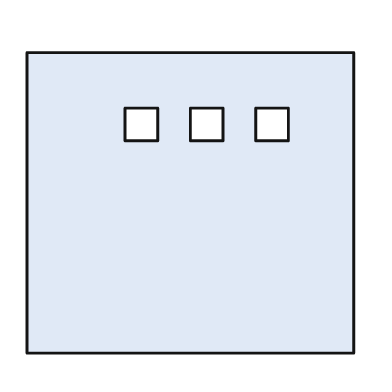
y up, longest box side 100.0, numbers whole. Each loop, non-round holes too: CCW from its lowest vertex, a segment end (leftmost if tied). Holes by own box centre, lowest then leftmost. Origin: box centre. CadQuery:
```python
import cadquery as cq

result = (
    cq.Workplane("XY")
    .moveTo(-50.0, -46.0)
    .lineTo(50.0, -46.0)
    .lineTo(50.0, 46.0)
    .lineTo(-50.0, 46.0)
    .close()
    .moveTo(-20.0, 19.0)
    .lineTo(-10.0, 19.0)
    .lineTo(-10.0, 29.0)
    .lineTo(-20.0, 29.0)
    .close()
    .moveTo(0.0, 19.0)
    .lineTo(10.0, 19.0)
    .lineTo(10.0, 29.0)
    .lineTo(0.0, 29.0)
    .close()
    .moveTo(20.0, 19.0)
    .lineTo(30.0, 19.0)
    .lineTo(30.0, 29.0)
    .lineTo(20.0, 29.0)
    .close()
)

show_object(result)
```